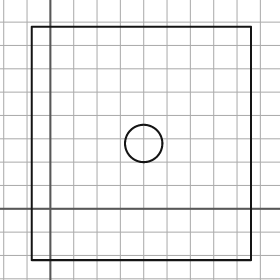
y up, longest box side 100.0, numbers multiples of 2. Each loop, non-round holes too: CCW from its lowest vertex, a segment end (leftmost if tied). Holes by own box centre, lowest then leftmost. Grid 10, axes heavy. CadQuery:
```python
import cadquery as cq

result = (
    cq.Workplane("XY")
    .moveTo(-8.0, -22.0)
    .lineTo(86.0, -22.0)
    .lineTo(86.0, 78.0)
    .lineTo(-8.0, 78.0)
    .close()
    .moveTo(40.0, 28.0)
    .circle(8.0)
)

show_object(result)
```